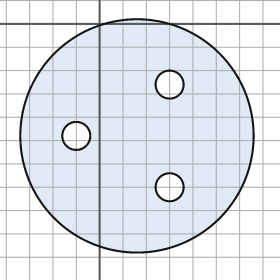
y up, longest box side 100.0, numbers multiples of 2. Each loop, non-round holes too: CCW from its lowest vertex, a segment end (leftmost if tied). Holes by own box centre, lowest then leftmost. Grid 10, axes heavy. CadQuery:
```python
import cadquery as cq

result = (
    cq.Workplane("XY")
    .moveTo(16.0, -48.0)
    .circle(50.0)
    .moveTo(30.0, -70.0)
    .circle(6.0)
    .moveTo(-10.0, -48.0)
    .circle(6.0)
    .moveTo(30.0, -26.0)
    .circle(6.0)
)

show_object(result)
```